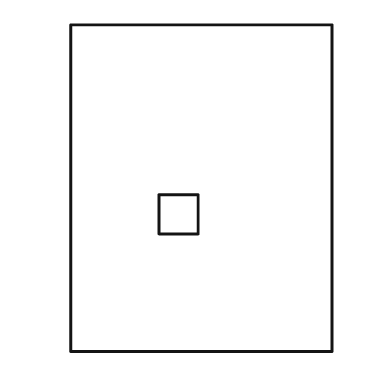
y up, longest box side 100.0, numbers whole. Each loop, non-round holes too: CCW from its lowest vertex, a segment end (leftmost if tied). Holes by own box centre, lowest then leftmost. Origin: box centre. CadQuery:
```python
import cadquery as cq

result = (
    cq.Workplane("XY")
    .moveTo(-40.0, -50.0)
    .lineTo(40.0, -50.0)
    .lineTo(40.0, 50.0)
    .lineTo(-40.0, 50.0)
    .close()
    .moveTo(-13.0, -14.0)
    .lineTo(-1.0, -14.0)
    .lineTo(-1.0, -2.0)
    .lineTo(-13.0, -2.0)
    .close()
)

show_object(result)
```